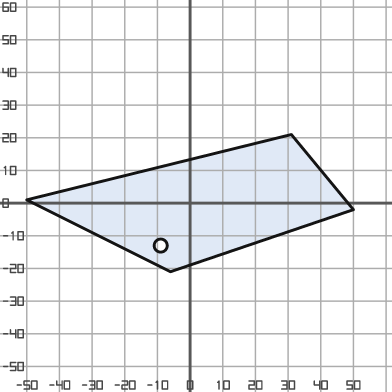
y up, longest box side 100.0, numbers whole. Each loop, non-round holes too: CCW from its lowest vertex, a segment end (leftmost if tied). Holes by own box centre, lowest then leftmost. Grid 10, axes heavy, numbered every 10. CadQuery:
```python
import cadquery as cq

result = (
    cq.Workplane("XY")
    .moveTo(-6.0, -21.0)
    .lineTo(50.0, -2.0)
    .lineTo(31.0, 21.0)
    .lineTo(-50.0, 1.0)
    .close()
    .moveTo(-9.0, -13.0)
    .circle(2.0)
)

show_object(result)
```